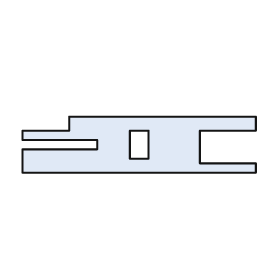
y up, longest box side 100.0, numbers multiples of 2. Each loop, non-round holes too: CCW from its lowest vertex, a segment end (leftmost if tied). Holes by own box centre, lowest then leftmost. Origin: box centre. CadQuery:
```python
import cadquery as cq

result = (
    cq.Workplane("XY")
    .moveTo(-50.0, -12.0)
    .lineTo(50.0, -12.0)
    .lineTo(50.0, -8.0)
    .lineTo(26.0, -8.0)
    .lineTo(26.0, 6.0)
    .lineTo(50.0, 6.0)
    .lineTo(50.0, 12.0)
    .lineTo(-30.0, 12.0)
    .lineTo(-30.0, 6.0)
    .lineTo(-50.0, 6.0)
    .lineTo(-50.0, 2.0)
    .lineTo(-18.0, 2.0)
    .lineTo(-18.0, -2.0)
    .lineTo(-50.0, -2.0)
    .close()
    .moveTo(-4.0, -6.0)
    .lineTo(4.0, -6.0)
    .lineTo(4.0, 6.0)
    .lineTo(-4.0, 6.0)
    .close()
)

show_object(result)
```